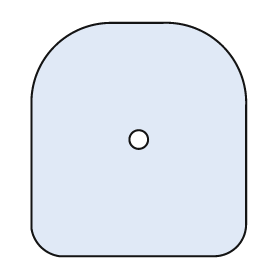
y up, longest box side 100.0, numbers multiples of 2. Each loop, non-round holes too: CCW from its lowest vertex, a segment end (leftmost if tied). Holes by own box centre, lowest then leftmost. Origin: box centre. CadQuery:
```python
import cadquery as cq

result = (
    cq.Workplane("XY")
    .moveTo(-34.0, -50.0)
    .lineTo(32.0, -50.0)
    .threePointArc((42.0, -46.0), (46.0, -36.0))
    .lineTo(46.0, 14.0)
    .threePointArc((36.0, 40.0), (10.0, 50.0))
    .lineTo(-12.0, 50.0)
    .threePointArc((-36.0, 40.0), (-46.0, 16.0))
    .lineTo(-46.0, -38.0)
    .threePointArc((-42.0, -46.0), (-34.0, -50.0))
    .close()
    .moveTo(0.0, 0.0)
    .circle(4.0)
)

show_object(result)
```